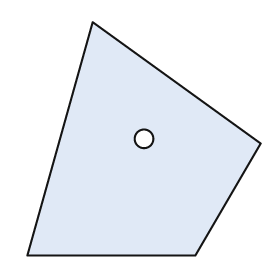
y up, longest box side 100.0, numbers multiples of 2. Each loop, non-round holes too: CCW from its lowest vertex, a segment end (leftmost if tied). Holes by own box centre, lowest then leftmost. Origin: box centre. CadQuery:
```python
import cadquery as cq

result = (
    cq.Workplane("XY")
    .moveTo(-50.0, -50.0)
    .lineTo(22.0, -50.0)
    .lineTo(50.0, -2.0)
    .lineTo(-22.0, 50.0)
    .close()
    .moveTo(0.0, 0.0)
    .circle(4.0)
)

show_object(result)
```